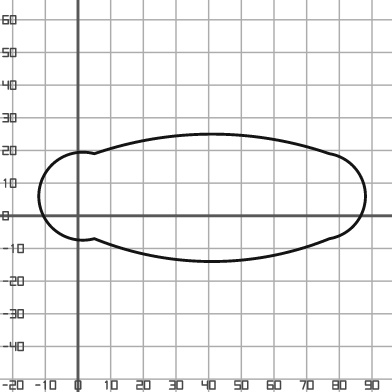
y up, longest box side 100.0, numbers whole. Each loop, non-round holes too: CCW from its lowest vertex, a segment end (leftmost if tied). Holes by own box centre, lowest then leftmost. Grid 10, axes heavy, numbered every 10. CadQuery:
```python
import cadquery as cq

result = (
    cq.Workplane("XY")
    .moveTo(5.0, -7.0)
    .threePointArc((41.0, -14.0), (77.0, -7.0))
    .threePointArc((88.0, 6.0), (77.0, 19.0))
    .threePointArc((41.0, 25.0), (5.0, 19.0))
    .threePointArc((-12.0, 6.0), (5.0, -7.0))
    .close()
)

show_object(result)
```